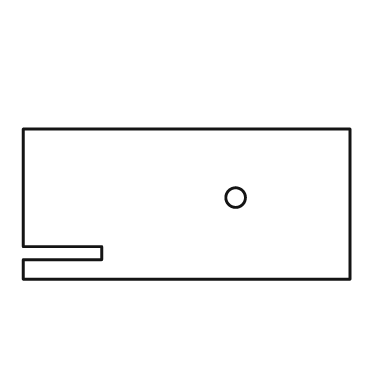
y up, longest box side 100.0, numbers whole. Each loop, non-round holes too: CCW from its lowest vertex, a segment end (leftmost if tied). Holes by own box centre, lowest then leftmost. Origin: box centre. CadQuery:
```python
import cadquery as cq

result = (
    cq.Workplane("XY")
    .moveTo(-50.0, -23.0)
    .lineTo(50.0, -23.0)
    .lineTo(50.0, 23.0)
    .lineTo(-50.0, 23.0)
    .lineTo(-50.0, -13.0)
    .lineTo(-26.0, -13.0)
    .lineTo(-26.0, -17.0)
    .lineTo(-50.0, -17.0)
    .close()
    .moveTo(15.0, 2.0)
    .circle(3.0)
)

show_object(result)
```